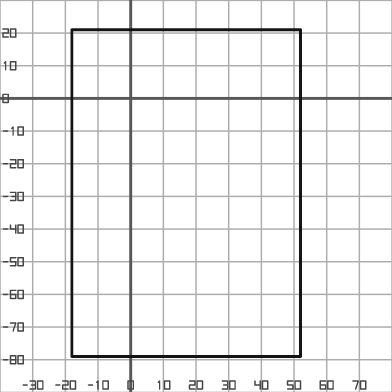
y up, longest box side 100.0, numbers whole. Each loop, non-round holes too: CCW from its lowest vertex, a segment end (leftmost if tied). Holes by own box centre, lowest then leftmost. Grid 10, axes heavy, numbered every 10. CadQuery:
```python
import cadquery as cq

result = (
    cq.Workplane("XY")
    .moveTo(-18.0, -79.0)
    .lineTo(52.0, -79.0)
    .lineTo(52.0, 21.0)
    .lineTo(-18.0, 21.0)
    .close()
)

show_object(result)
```